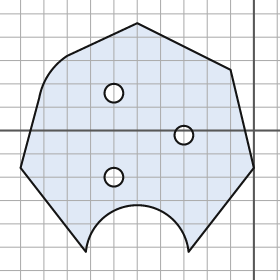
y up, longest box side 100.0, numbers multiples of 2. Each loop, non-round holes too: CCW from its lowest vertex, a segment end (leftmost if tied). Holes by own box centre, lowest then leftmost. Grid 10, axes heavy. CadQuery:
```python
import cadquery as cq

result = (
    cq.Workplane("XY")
    .moveTo(-72.0, -52.0)
    .threePointArc((-50.0, -32.0), (-28.0, -52.0))
    .lineTo(0.0, -16.0)
    .lineTo(-10.0, 26.0)
    .lineTo(-50.0, 46.0)
    .lineTo(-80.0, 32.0)
    .threePointArc((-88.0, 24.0), (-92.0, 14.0))
    .lineTo(-100.0, -16.0)
    .close()
    .moveTo(-60.0, -20.0)
    .circle(4.0)
    .moveTo(-30.0, -2.0)
    .circle(4.0)
    .moveTo(-60.0, 16.0)
    .circle(4.0)
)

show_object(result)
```